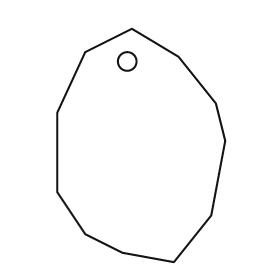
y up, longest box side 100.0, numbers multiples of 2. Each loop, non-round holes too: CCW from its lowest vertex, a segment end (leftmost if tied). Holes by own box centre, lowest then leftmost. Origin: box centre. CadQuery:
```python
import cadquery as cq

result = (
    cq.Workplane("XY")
    .moveTo(14.0, -50.0)
    .lineTo(30.0, -30.0)
    .lineTo(36.0, 2.0)
    .lineTo(32.0, 18.0)
    .lineTo(16.0, 38.0)
    .lineTo(-4.0, 50.0)
    .lineTo(-24.0, 40.0)
    .lineTo(-36.0, 14.0)
    .lineTo(-36.0, -20.0)
    .lineTo(-24.0, -38.0)
    .lineTo(-8.0, -46.0)
    .close()
    .moveTo(-6.0, 36.0)
    .circle(4.0)
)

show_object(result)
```